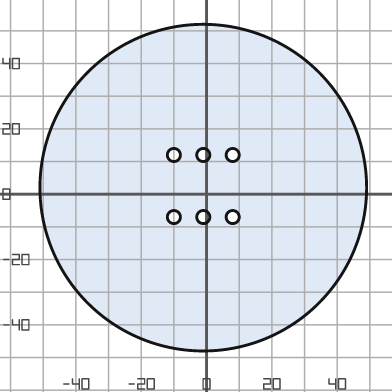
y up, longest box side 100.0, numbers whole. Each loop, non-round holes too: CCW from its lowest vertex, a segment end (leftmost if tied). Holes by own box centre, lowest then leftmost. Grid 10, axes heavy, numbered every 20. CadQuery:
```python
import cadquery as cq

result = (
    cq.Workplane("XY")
    .moveTo(-1.0, 2.0)
    .circle(50.0)
    .moveTo(-10.0, -7.0)
    .circle(2.0)
    .moveTo(-1.0, -7.0)
    .circle(2.0)
    .moveTo(8.0, -7.0)
    .circle(2.0)
    .moveTo(-10.0, 12.0)
    .circle(2.0)
    .moveTo(-1.0, 12.0)
    .circle(2.0)
    .moveTo(8.0, 12.0)
    .circle(2.0)
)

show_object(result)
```